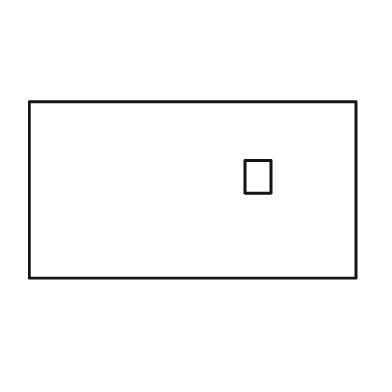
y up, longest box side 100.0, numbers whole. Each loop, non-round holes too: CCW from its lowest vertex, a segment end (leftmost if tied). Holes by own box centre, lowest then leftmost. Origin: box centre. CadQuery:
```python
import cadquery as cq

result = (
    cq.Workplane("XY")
    .moveTo(-50.0, -27.0)
    .lineTo(50.0, -27.0)
    .lineTo(50.0, 27.0)
    .lineTo(-50.0, 27.0)
    .close()
    .moveTo(16.0, -1.0)
    .lineTo(24.0, -1.0)
    .lineTo(24.0, 9.0)
    .lineTo(16.0, 9.0)
    .close()
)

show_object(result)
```